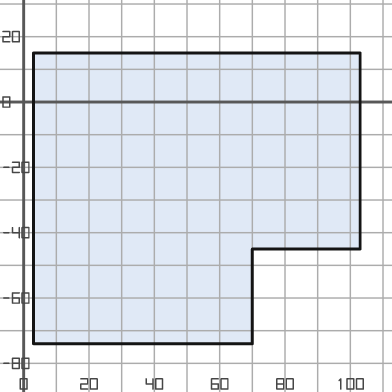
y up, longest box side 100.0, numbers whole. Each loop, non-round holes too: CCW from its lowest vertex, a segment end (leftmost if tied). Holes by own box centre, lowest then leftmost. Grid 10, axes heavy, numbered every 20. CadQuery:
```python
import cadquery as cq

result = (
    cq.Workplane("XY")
    .moveTo(3.0, -74.0)
    .lineTo(70.0, -74.0)
    .lineTo(70.0, -45.0)
    .lineTo(103.0, -45.0)
    .lineTo(103.0, 15.0)
    .lineTo(3.0, 15.0)
    .close()
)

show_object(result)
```